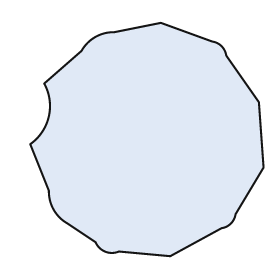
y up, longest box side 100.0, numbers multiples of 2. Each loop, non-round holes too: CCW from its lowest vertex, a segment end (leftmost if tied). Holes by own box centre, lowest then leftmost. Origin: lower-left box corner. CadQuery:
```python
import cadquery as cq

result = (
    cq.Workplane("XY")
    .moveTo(60.0, 0.0)
    .lineTo(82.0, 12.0)
    .threePointArc((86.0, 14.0), (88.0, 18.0))
    .lineTo(100.0, 38.0)
    .lineTo(98.0, 66.0)
    .lineTo(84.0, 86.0)
    .threePointArc((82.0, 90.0), (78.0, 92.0))
    .lineTo(56.0, 100.0)
    .lineTo(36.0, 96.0)
    .threePointArc((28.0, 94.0), (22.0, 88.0))
    .lineTo(6.0, 74.0)
    .threePointArc((8.0, 60.0), (0.0, 48.0))
    .lineTo(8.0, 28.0)
    .threePointArc((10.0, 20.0), (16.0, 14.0))
    .lineTo(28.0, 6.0)
    .threePointArc((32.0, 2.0), (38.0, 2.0))
    .close()
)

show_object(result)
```